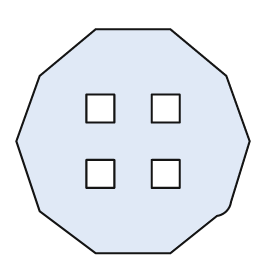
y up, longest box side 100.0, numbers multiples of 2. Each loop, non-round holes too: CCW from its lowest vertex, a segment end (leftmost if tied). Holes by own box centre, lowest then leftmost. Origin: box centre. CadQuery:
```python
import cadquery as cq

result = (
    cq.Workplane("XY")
    .moveTo(-16.0, -48.0)
    .lineTo(16.0, -48.0)
    .lineTo(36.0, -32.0)
    .threePointArc((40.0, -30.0), (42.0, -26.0))
    .lineTo(50.0, 0.0)
    .lineTo(40.0, 28.0)
    .lineTo(16.0, 48.0)
    .lineTo(-16.0, 48.0)
    .lineTo(-40.0, 28.0)
    .lineTo(-50.0, 0.0)
    .lineTo(-40.0, -30.0)
    .close()
    .moveTo(-20.0, -20.0)
    .lineTo(-8.0, -20.0)
    .lineTo(-8.0, -8.0)
    .lineTo(-20.0, -8.0)
    .close()
    .moveTo(8.0, -20.0)
    .lineTo(20.0, -20.0)
    .lineTo(20.0, -8.0)
    .lineTo(8.0, -8.0)
    .close()
    .moveTo(-20.0, 8.0)
    .lineTo(-8.0, 8.0)
    .lineTo(-8.0, 20.0)
    .lineTo(-20.0, 20.0)
    .close()
    .moveTo(8.0, 8.0)
    .lineTo(20.0, 8.0)
    .lineTo(20.0, 20.0)
    .lineTo(8.0, 20.0)
    .close()
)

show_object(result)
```